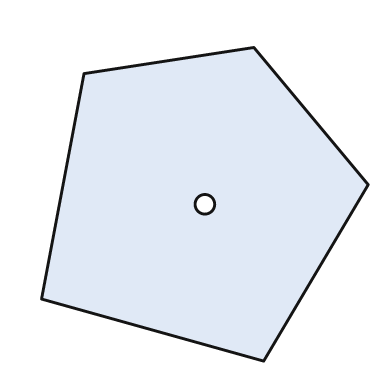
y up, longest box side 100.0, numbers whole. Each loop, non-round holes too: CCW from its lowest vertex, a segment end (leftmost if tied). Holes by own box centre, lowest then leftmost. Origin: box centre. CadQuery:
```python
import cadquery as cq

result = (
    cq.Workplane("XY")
    .moveTo(18.0, -48.0)
    .lineTo(50.0, 6.0)
    .lineTo(15.0, 48.0)
    .lineTo(-37.0, 40.0)
    .lineTo(-50.0, -29.0)
    .close()
    .moveTo(0.0, 0.0)
    .circle(3.0)
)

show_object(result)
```